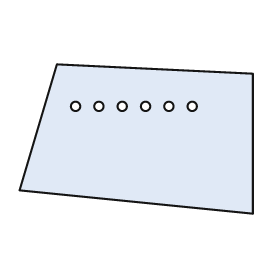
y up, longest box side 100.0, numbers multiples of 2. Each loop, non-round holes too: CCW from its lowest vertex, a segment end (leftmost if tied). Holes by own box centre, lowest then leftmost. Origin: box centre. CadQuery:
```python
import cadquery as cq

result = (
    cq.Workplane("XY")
    .moveTo(50.0, -32.0)
    .lineTo(50.0, 28.0)
    .lineTo(-34.0, 32.0)
    .lineTo(-50.0, -22.0)
    .close()
    .moveTo(-26.0, 14.0)
    .circle(2.0)
    .moveTo(-16.0, 14.0)
    .circle(2.0)
    .moveTo(-6.0, 14.0)
    .circle(2.0)
    .moveTo(4.0, 14.0)
    .circle(2.0)
    .moveTo(14.0, 14.0)
    .circle(2.0)
    .moveTo(24.0, 14.0)
    .circle(2.0)
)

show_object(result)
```